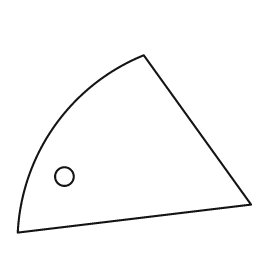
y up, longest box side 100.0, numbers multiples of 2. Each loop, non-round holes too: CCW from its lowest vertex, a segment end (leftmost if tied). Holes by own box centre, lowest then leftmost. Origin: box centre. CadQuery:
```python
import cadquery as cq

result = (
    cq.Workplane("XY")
    .moveTo(-50.0, -38.0)
    .lineTo(50.0, -26.0)
    .lineTo(4.0, 38.0)
    .threePointArc((-34.0, 8.0), (-50.0, -38.0))
    .close()
    .moveTo(-30.0, -14.0)
    .circle(4.0)
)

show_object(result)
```